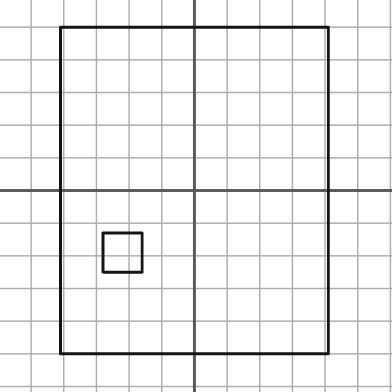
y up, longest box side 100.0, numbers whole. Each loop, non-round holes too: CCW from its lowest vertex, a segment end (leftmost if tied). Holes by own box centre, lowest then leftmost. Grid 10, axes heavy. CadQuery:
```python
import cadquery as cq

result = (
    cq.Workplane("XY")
    .moveTo(-41.0, -50.0)
    .lineTo(41.0, -50.0)
    .lineTo(41.0, 50.0)
    .lineTo(-41.0, 50.0)
    .close()
    .moveTo(-28.0, -25.0)
    .lineTo(-16.0, -25.0)
    .lineTo(-16.0, -13.0)
    .lineTo(-28.0, -13.0)
    .close()
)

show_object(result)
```